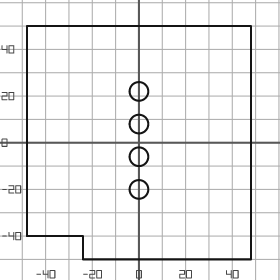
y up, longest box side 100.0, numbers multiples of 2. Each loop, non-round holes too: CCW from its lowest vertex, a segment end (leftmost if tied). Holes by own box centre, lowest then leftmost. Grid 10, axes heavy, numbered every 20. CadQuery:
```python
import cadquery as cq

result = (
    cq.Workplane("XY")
    .moveTo(-24.0, -50.0)
    .lineTo(48.0, -50.0)
    .lineTo(48.0, 50.0)
    .lineTo(-48.0, 50.0)
    .lineTo(-48.0, -40.0)
    .lineTo(-24.0, -40.0)
    .close()
    .moveTo(0.0, -20.0)
    .circle(4.0)
    .moveTo(0.0, -6.0)
    .circle(4.0)
    .moveTo(0.0, 8.0)
    .circle(4.0)
    .moveTo(0.0, 22.0)
    .circle(4.0)
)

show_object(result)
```